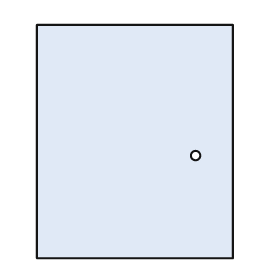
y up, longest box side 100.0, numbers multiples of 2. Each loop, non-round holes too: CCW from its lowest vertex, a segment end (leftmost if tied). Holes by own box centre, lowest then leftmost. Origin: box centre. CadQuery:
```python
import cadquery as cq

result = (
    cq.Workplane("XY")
    .moveTo(-42.0, -50.0)
    .lineTo(42.0, -50.0)
    .lineTo(42.0, 50.0)
    .lineTo(-42.0, 50.0)
    .close()
    .moveTo(26.0, -6.0)
    .circle(2.0)
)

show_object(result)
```